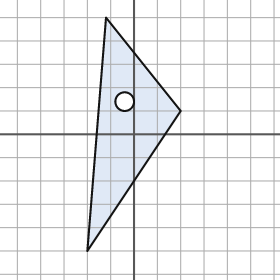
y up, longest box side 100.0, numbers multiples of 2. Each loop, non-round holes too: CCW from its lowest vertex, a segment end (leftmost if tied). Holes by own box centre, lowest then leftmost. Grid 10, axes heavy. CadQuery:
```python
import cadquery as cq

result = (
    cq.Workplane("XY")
    .moveTo(-20.0, -50.0)
    .lineTo(20.0, 10.0)
    .lineTo(-12.0, 50.0)
    .close()
    .moveTo(-4.0, 14.0)
    .circle(4.0)
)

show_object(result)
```